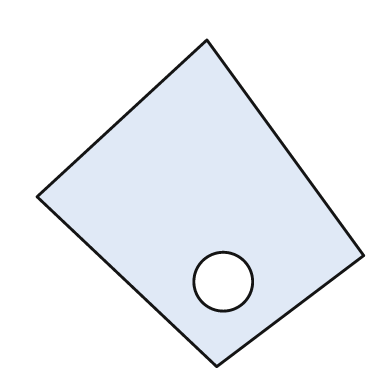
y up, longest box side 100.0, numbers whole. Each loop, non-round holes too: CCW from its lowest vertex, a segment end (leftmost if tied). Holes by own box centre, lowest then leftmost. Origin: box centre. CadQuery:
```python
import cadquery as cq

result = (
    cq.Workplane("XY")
    .moveTo(5.0, -50.0)
    .lineTo(50.0, -16.0)
    .lineTo(2.0, 50.0)
    .lineTo(-50.0, 2.0)
    .close()
    .moveTo(7.0, -24.0)
    .circle(9.0)
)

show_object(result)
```